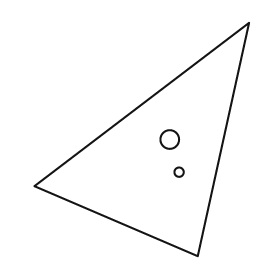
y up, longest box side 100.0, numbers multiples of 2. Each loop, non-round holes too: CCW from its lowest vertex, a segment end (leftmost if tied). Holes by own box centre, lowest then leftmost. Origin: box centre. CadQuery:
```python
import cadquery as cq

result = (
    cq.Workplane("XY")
    .moveTo(24.0, -50.0)
    .lineTo(46.0, 50.0)
    .lineTo(-46.0, -20.0)
    .close()
    .moveTo(16.0, -14.0)
    .circle(2.0)
    .moveTo(12.0, 0.0)
    .circle(4.0)
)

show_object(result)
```